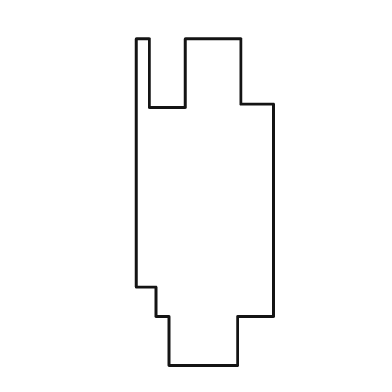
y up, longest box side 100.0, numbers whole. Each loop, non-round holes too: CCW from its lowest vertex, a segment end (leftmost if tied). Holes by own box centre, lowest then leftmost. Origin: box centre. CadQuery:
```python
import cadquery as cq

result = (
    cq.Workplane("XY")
    .moveTo(-11.0, -50.0)
    .lineTo(10.0, -50.0)
    .lineTo(10.0, -35.0)
    .lineTo(21.0, -35.0)
    .lineTo(21.0, 30.0)
    .lineTo(11.0, 30.0)
    .lineTo(11.0, 50.0)
    .lineTo(-6.0, 50.0)
    .lineTo(-6.0, 29.0)
    .lineTo(-17.0, 29.0)
    .lineTo(-17.0, 50.0)
    .lineTo(-21.0, 50.0)
    .lineTo(-21.0, -26.0)
    .lineTo(-15.0, -26.0)
    .lineTo(-15.0, -35.0)
    .lineTo(-11.0, -35.0)
    .close()
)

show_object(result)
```